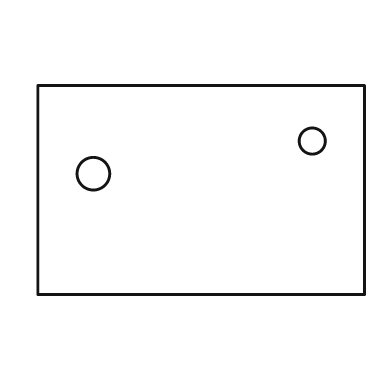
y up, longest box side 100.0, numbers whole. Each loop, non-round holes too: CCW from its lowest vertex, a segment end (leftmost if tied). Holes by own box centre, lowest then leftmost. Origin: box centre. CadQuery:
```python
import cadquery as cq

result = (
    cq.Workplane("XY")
    .moveTo(-50.0, -32.0)
    .lineTo(50.0, -32.0)
    .lineTo(50.0, 32.0)
    .lineTo(-50.0, 32.0)
    .close()
    .moveTo(-33.0, 5.0)
    .circle(5.0)
    .moveTo(34.0, 15.0)
    .circle(4.0)
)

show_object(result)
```